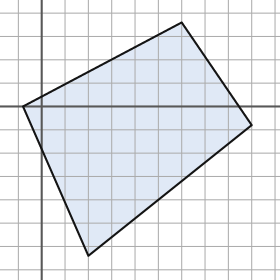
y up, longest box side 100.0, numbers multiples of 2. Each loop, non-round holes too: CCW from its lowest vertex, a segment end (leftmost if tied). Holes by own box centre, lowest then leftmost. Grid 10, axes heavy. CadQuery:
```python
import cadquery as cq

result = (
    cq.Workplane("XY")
    .moveTo(20.0, -64.0)
    .lineTo(90.0, -8.0)
    .lineTo(60.0, 36.0)
    .lineTo(-8.0, 0.0)
    .close()
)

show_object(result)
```